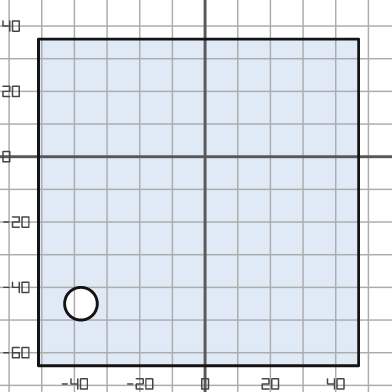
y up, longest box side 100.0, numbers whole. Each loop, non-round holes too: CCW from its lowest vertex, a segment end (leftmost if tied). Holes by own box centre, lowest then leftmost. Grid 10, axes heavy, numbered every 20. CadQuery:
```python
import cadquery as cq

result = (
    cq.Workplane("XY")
    .moveTo(-51.0, -64.0)
    .lineTo(47.0, -64.0)
    .lineTo(47.0, 36.0)
    .lineTo(-51.0, 36.0)
    .close()
    .moveTo(-38.0, -45.0)
    .circle(5.0)
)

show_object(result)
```